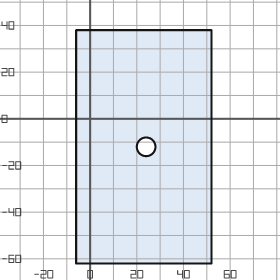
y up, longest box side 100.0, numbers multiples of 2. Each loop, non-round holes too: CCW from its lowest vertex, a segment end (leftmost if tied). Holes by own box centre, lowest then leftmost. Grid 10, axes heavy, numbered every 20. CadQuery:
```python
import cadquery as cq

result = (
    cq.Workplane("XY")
    .moveTo(-6.0, -62.0)
    .lineTo(52.0, -62.0)
    .lineTo(52.0, 38.0)
    .lineTo(-6.0, 38.0)
    .close()
    .moveTo(24.0, -12.0)
    .circle(4.0)
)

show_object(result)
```